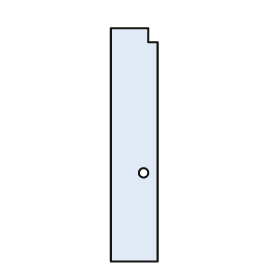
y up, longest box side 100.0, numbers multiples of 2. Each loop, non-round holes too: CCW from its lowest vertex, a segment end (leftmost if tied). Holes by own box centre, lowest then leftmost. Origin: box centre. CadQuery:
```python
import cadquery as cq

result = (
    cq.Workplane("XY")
    .moveTo(-10.0, -50.0)
    .lineTo(10.0, -50.0)
    .lineTo(10.0, 44.0)
    .lineTo(6.0, 44.0)
    .lineTo(6.0, 50.0)
    .lineTo(-10.0, 50.0)
    .close()
    .moveTo(4.0, -12.0)
    .circle(2.0)
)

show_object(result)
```